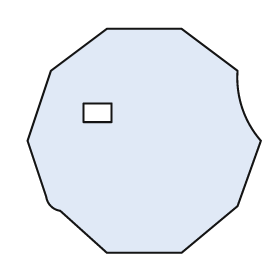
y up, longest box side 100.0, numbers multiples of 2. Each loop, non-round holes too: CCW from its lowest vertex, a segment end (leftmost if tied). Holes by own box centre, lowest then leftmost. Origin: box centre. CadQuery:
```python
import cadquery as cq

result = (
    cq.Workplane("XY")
    .moveTo(-16.0, -48.0)
    .lineTo(16.0, -48.0)
    .lineTo(40.0, -28.0)
    .lineTo(50.0, 0.0)
    .threePointArc((42.0, 14.0), (40.0, 30.0))
    .lineTo(16.0, 48.0)
    .lineTo(-16.0, 48.0)
    .lineTo(-40.0, 30.0)
    .lineTo(-50.0, 0.0)
    .lineTo(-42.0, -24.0)
    .threePointArc((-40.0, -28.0), (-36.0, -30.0))
    .close()
    .moveTo(-26.0, 8.0)
    .lineTo(-14.0, 8.0)
    .lineTo(-14.0, 16.0)
    .lineTo(-26.0, 16.0)
    .close()
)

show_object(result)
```